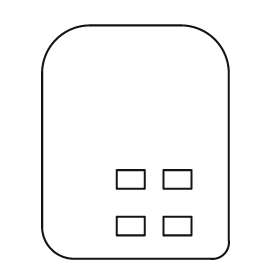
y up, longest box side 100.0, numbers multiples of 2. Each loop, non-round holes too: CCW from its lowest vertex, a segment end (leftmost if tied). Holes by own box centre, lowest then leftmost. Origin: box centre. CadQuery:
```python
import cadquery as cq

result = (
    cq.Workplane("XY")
    .moveTo(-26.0, -50.0)
    .lineTo(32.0, -50.0)
    .threePointArc((38.0, -48.0), (40.0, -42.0))
    .lineTo(40.0, 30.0)
    .threePointArc((34.0, 44.0), (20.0, 50.0))
    .lineTo(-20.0, 50.0)
    .threePointArc((-34.0, 44.0), (-40.0, 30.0))
    .lineTo(-40.0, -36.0)
    .threePointArc((-36.0, -46.0), (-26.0, -50.0))
    .close()
    .moveTo(-8.0, -40.0)
    .lineTo(4.0, -40.0)
    .lineTo(4.0, -32.0)
    .lineTo(-8.0, -32.0)
    .close()
    .moveTo(12.0, -40.0)
    .lineTo(24.0, -40.0)
    .lineTo(24.0, -32.0)
    .lineTo(12.0, -32.0)
    .close()
    .moveTo(-8.0, -20.0)
    .lineTo(4.0, -20.0)
    .lineTo(4.0, -12.0)
    .lineTo(-8.0, -12.0)
    .close()
    .moveTo(12.0, -20.0)
    .lineTo(24.0, -20.0)
    .lineTo(24.0, -12.0)
    .lineTo(12.0, -12.0)
    .close()
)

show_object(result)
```